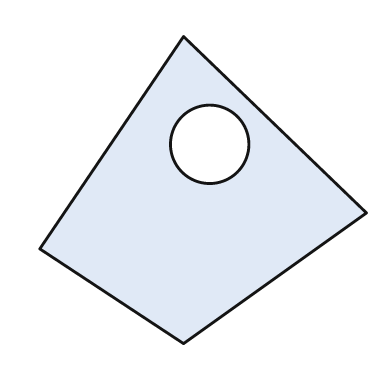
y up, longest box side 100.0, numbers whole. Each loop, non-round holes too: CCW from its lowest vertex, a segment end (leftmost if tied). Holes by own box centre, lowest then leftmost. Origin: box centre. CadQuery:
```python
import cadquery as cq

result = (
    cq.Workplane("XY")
    .moveTo(-6.0, -47.0)
    .lineTo(50.0, -7.0)
    .lineTo(-6.0, 47.0)
    .lineTo(-50.0, -18.0)
    .close()
    .moveTo(2.0, 14.0)
    .circle(12.0)
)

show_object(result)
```